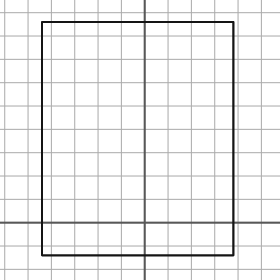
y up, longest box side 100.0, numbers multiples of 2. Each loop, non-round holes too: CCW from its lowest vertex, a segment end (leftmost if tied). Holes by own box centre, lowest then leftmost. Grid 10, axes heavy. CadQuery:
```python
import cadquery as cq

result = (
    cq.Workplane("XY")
    .moveTo(-44.0, -14.0)
    .lineTo(38.0, -14.0)
    .lineTo(38.0, 86.0)
    .lineTo(-44.0, 86.0)
    .close()
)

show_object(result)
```